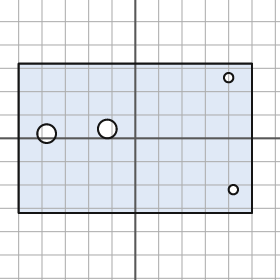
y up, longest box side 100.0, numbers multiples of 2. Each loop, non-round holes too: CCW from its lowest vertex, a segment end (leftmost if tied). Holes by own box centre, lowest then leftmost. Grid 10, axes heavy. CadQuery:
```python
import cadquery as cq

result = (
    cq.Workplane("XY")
    .moveTo(-50.0, -32.0)
    .lineTo(50.0, -32.0)
    .lineTo(50.0, 32.0)
    .lineTo(-50.0, 32.0)
    .close()
    .moveTo(42.0, -22.0)
    .circle(2.0)
    .moveTo(-38.0, 2.0)
    .circle(4.0)
    .moveTo(-12.0, 4.0)
    .circle(4.0)
    .moveTo(40.0, 26.0)
    .circle(2.0)
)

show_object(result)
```